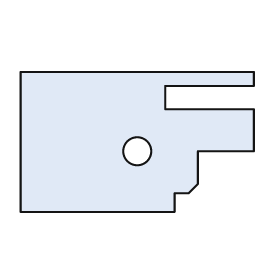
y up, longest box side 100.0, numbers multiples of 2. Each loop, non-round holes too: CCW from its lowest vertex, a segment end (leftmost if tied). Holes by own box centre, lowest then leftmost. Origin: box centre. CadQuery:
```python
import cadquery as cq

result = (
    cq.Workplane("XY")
    .moveTo(-50.0, -30.0)
    .lineTo(16.0, -30.0)
    .lineTo(16.0, -22.0)
    .lineTo(22.0, -22.0)
    .lineTo(26.0, -18.0)
    .lineTo(26.0, -4.0)
    .lineTo(50.0, -4.0)
    .lineTo(50.0, 14.0)
    .lineTo(12.0, 14.0)
    .lineTo(12.0, 24.0)
    .lineTo(50.0, 24.0)
    .lineTo(50.0, 30.0)
    .lineTo(-50.0, 30.0)
    .close()
    .moveTo(0.0, -4.0)
    .circle(6.0)
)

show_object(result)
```